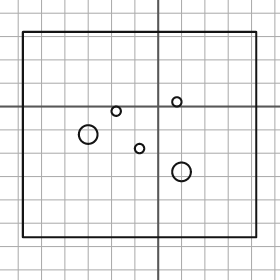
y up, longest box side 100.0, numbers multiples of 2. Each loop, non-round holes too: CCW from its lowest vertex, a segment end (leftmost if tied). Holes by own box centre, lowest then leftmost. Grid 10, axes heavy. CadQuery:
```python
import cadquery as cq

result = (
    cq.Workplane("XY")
    .moveTo(-58.0, -56.0)
    .lineTo(42.0, -56.0)
    .lineTo(42.0, 32.0)
    .lineTo(-58.0, 32.0)
    .close()
    .moveTo(10.0, -28.0)
    .circle(4.0)
    .moveTo(-8.0, -18.0)
    .circle(2.0)
    .moveTo(-30.0, -12.0)
    .circle(4.0)
    .moveTo(-18.0, -2.0)
    .circle(2.0)
    .moveTo(8.0, 2.0)
    .circle(2.0)
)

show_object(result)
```